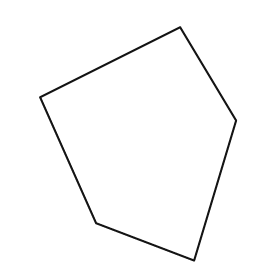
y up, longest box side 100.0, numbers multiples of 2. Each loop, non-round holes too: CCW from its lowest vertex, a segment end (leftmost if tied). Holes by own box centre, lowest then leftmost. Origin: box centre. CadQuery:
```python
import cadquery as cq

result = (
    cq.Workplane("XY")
    .moveTo(24.0, -50.0)
    .lineTo(42.0, 10.0)
    .lineTo(18.0, 50.0)
    .lineTo(-42.0, 20.0)
    .lineTo(-18.0, -34.0)
    .close()
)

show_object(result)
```